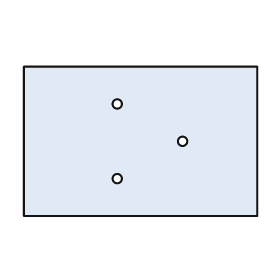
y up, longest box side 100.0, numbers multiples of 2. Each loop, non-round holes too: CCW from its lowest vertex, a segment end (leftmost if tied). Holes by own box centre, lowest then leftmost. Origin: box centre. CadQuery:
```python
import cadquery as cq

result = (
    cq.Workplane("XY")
    .moveTo(-50.0, -32.0)
    .lineTo(50.0, -32.0)
    .lineTo(50.0, 32.0)
    .lineTo(-50.0, 32.0)
    .close()
    .moveTo(-10.0, -16.0)
    .circle(2.0)
    .moveTo(18.0, 0.0)
    .circle(2.0)
    .moveTo(-10.0, 16.0)
    .circle(2.0)
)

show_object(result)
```